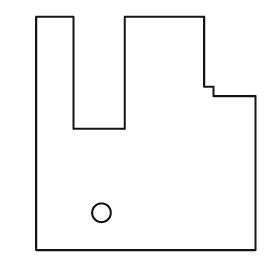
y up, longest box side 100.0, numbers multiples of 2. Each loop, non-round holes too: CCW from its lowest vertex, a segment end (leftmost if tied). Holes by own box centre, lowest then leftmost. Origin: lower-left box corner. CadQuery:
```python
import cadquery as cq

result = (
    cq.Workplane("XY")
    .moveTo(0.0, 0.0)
    .lineTo(94.0, 0.0)
    .lineTo(94.0, 66.0)
    .lineTo(76.0, 66.0)
    .lineTo(76.0, 70.0)
    .lineTo(72.0, 70.0)
    .lineTo(72.0, 100.0)
    .lineTo(38.0, 100.0)
    .lineTo(38.0, 52.0)
    .lineTo(16.0, 52.0)
    .lineTo(16.0, 100.0)
    .lineTo(0.0, 100.0)
    .close()
    .moveTo(28.0, 16.0)
    .circle(4.0)
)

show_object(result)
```